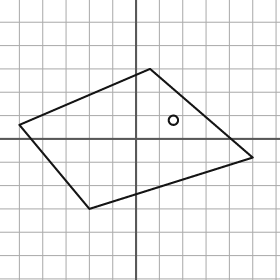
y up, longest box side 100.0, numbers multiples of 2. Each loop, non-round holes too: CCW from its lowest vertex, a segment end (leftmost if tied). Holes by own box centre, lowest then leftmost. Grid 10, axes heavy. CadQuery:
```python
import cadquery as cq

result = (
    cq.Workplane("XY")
    .moveTo(-20.0, -30.0)
    .lineTo(50.0, -8.0)
    .lineTo(6.0, 30.0)
    .lineTo(-50.0, 6.0)
    .close()
    .moveTo(16.0, 8.0)
    .circle(2.0)
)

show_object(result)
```